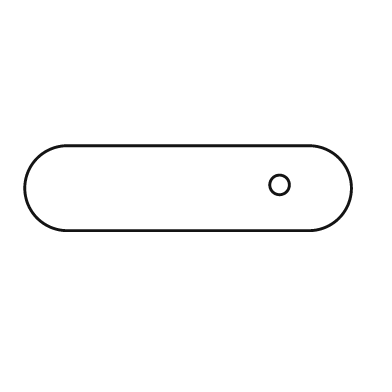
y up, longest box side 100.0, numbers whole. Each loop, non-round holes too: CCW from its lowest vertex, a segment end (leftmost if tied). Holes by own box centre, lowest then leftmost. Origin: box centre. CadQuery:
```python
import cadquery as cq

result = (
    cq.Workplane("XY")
    .moveTo(-37.0, -13.0)
    .lineTo(37.0, -13.0)
    .threePointArc((50.0, 0.0), (37.0, 13.0))
    .lineTo(-37.0, 13.0)
    .threePointArc((-50.0, 0.0), (-37.0, -13.0))
    .close()
    .moveTo(28.0, 1.0)
    .circle(3.0)
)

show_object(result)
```